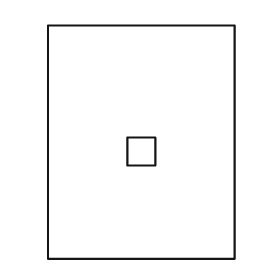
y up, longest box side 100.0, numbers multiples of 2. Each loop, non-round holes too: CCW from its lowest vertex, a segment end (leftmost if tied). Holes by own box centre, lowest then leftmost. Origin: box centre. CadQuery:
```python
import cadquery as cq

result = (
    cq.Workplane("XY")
    .moveTo(-40.0, -50.0)
    .lineTo(40.0, -50.0)
    .lineTo(40.0, 50.0)
    .lineTo(-40.0, 50.0)
    .close()
    .moveTo(-6.0, -10.0)
    .lineTo(6.0, -10.0)
    .lineTo(6.0, 2.0)
    .lineTo(-6.0, 2.0)
    .close()
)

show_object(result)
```